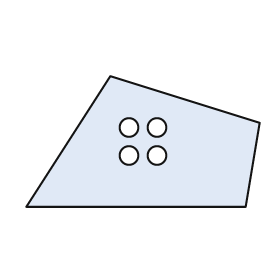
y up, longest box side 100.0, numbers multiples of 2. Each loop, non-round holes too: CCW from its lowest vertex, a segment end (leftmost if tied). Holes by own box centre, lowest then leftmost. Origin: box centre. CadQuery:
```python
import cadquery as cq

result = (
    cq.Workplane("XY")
    .moveTo(-50.0, -28.0)
    .lineTo(44.0, -28.0)
    .lineTo(50.0, 8.0)
    .lineTo(-14.0, 28.0)
    .close()
    .moveTo(-6.0, -6.0)
    .circle(4.0)
    .moveTo(6.0, -6.0)
    .circle(4.0)
    .moveTo(-6.0, 6.0)
    .circle(4.0)
    .moveTo(6.0, 6.0)
    .circle(4.0)
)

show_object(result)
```